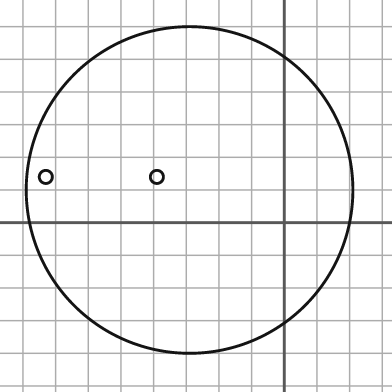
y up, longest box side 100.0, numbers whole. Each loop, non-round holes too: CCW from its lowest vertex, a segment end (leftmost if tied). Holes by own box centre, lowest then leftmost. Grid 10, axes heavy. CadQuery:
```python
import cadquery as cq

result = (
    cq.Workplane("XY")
    .moveTo(-29.0, 10.0)
    .circle(50.0)
    .moveTo(-73.0, 14.0)
    .circle(2.0)
    .moveTo(-39.0, 14.0)
    .circle(2.0)
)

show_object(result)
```